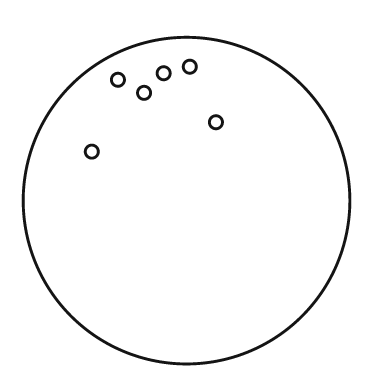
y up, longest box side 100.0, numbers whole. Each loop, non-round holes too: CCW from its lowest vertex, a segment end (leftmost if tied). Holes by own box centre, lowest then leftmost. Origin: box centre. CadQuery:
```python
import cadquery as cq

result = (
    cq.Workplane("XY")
    .moveTo(0.0, 0.0)
    .circle(50.0)
    .moveTo(-29.0, 15.0)
    .circle(2.0)
    .moveTo(9.0, 24.0)
    .circle(2.0)
    .moveTo(-13.0, 33.0)
    .circle(2.0)
    .moveTo(-21.0, 37.0)
    .circle(2.0)
    .moveTo(-7.0, 39.0)
    .circle(2.0)
    .moveTo(1.0, 41.0)
    .circle(2.0)
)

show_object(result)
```